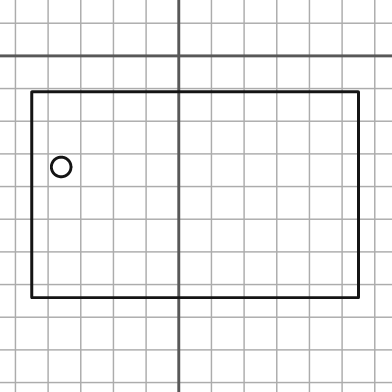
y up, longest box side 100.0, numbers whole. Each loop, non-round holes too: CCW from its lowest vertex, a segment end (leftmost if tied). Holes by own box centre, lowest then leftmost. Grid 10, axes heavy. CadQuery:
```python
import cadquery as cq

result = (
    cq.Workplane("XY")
    .moveTo(-45.0, -74.0)
    .lineTo(55.0, -74.0)
    .lineTo(55.0, -11.0)
    .lineTo(-45.0, -11.0)
    .close()
    .moveTo(-36.0, -34.0)
    .circle(3.0)
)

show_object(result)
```